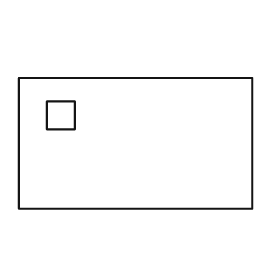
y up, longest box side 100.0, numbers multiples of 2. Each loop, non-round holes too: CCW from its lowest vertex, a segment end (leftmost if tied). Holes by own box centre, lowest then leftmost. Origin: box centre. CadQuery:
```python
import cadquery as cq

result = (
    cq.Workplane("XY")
    .moveTo(-50.0, -28.0)
    .lineTo(50.0, -28.0)
    .lineTo(50.0, 28.0)
    .lineTo(-50.0, 28.0)
    .close()
    .moveTo(-38.0, 6.0)
    .lineTo(-26.0, 6.0)
    .lineTo(-26.0, 18.0)
    .lineTo(-38.0, 18.0)
    .close()
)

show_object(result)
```